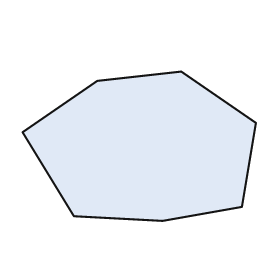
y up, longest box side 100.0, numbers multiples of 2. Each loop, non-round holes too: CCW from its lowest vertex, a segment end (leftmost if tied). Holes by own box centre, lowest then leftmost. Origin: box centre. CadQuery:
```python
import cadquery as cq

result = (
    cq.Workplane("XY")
    .moveTo(10.0, -32.0)
    .lineTo(44.0, -26.0)
    .lineTo(50.0, 10.0)
    .lineTo(18.0, 32.0)
    .lineTo(-18.0, 28.0)
    .lineTo(-50.0, 6.0)
    .lineTo(-28.0, -30.0)
    .close()
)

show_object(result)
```